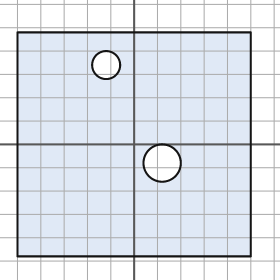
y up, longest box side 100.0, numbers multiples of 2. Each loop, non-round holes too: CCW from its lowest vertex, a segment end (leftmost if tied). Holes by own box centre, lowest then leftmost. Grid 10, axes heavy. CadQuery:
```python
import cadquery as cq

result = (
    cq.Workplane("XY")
    .moveTo(-50.0, -48.0)
    .lineTo(50.0, -48.0)
    .lineTo(50.0, 48.0)
    .lineTo(-50.0, 48.0)
    .close()
    .moveTo(12.0, -8.0)
    .circle(8.0)
    .moveTo(-12.0, 34.0)
    .circle(6.0)
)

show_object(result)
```